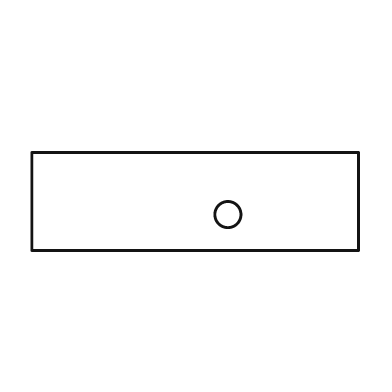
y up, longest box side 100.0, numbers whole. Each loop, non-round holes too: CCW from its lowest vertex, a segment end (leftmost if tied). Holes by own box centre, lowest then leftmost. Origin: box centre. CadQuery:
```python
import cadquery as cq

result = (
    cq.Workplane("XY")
    .moveTo(-50.0, -15.0)
    .lineTo(50.0, -15.0)
    .lineTo(50.0, 15.0)
    .lineTo(-50.0, 15.0)
    .close()
    .moveTo(10.0, -4.0)
    .circle(4.0)
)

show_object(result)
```